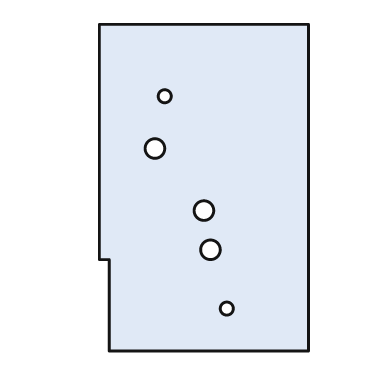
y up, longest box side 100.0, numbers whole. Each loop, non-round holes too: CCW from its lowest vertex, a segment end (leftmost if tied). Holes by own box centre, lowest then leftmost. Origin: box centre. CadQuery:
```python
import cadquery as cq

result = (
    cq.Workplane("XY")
    .moveTo(-29.0, -50.0)
    .lineTo(32.0, -50.0)
    .lineTo(32.0, 50.0)
    .lineTo(-32.0, 50.0)
    .lineTo(-32.0, -22.0)
    .lineTo(-29.0, -22.0)
    .close()
    .moveTo(7.0, -37.0)
    .circle(2.0)
    .moveTo(2.0, -19.0)
    .circle(3.0)
    .moveTo(0.0, -7.0)
    .circle(3.0)
    .moveTo(-15.0, 12.0)
    .circle(3.0)
    .moveTo(-12.0, 28.0)
    .circle(2.0)
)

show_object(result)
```